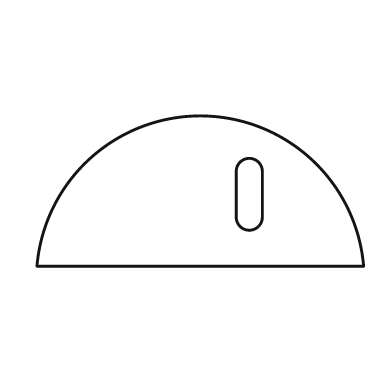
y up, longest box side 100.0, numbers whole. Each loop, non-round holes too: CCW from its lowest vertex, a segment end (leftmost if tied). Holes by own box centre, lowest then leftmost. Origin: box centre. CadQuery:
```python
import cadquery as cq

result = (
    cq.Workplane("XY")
    .moveTo(-50.0, -23.0)
    .lineTo(50.0, -23.0)
    .threePointArc((0.0, 23.0), (-50.0, -23.0))
    .close()
    .moveTo(11.0, -8.0)
    .threePointArc((15.0, -12.0), (19.0, -8.0))
    .lineTo(19.0, 6.0)
    .threePointArc((15.0, 10.0), (11.0, 6.0))
    .close()
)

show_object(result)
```